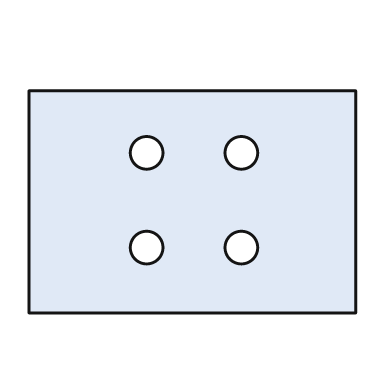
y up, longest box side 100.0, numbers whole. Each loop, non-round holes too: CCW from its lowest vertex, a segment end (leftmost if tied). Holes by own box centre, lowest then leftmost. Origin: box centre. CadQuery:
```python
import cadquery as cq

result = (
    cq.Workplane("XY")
    .moveTo(-50.0, -34.0)
    .lineTo(50.0, -34.0)
    .lineTo(50.0, 34.0)
    .lineTo(-50.0, 34.0)
    .close()
    .moveTo(-14.0, -14.0)
    .circle(5.0)
    .moveTo(15.0, -14.0)
    .circle(5.0)
    .moveTo(-14.0, 15.0)
    .circle(5.0)
    .moveTo(15.0, 15.0)
    .circle(5.0)
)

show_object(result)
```